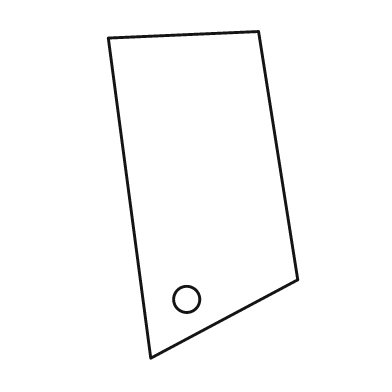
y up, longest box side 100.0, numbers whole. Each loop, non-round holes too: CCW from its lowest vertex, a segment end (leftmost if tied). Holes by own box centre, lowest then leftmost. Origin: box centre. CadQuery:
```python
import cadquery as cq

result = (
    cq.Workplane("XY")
    .moveTo(-16.0, -50.0)
    .lineTo(29.0, -26.0)
    .lineTo(17.0, 50.0)
    .lineTo(-29.0, 48.0)
    .close()
    .moveTo(-5.0, -32.0)
    .circle(4.0)
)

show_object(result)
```